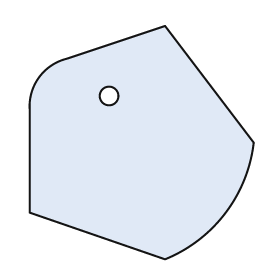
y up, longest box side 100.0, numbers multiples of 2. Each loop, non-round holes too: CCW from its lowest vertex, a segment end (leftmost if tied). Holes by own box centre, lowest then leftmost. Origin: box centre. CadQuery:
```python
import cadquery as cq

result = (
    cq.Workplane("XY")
    .moveTo(10.0, -50.0)
    .threePointArc((36.0, -30.0), (48.0, 0.0))
    .lineTo(10.0, 50.0)
    .lineTo(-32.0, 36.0)
    .threePointArc((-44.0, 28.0), (-48.0, 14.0))
    .lineTo(-48.0, -30.0)
    .close()
    .moveTo(-14.0, 20.0)
    .circle(4.0)
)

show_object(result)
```